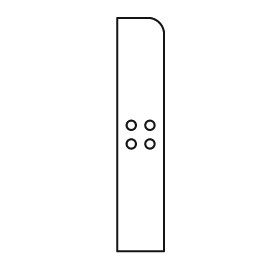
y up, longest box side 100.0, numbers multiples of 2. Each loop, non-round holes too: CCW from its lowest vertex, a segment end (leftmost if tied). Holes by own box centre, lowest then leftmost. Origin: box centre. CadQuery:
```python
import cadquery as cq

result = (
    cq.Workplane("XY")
    .moveTo(-10.0, -50.0)
    .lineTo(10.0, -50.0)
    .lineTo(10.0, 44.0)
    .threePointArc((8.0, 48.0), (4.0, 50.0))
    .lineTo(-10.0, 50.0)
    .close()
    .moveTo(-4.0, -4.0)
    .circle(2.0)
    .moveTo(4.0, -4.0)
    .circle(2.0)
    .moveTo(-4.0, 4.0)
    .circle(2.0)
    .moveTo(4.0, 4.0)
    .circle(2.0)
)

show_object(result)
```